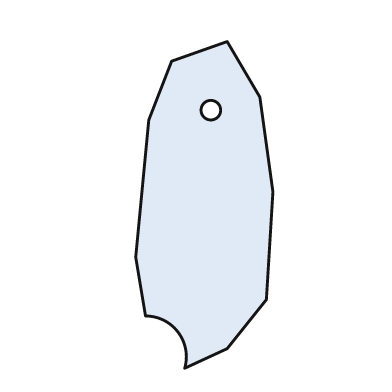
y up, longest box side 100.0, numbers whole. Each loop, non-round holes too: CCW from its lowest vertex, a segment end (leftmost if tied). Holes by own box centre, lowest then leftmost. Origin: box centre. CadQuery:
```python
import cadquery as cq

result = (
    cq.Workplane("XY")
    .moveTo(-6.0, -50.0)
    .lineTo(7.0, -44.0)
    .lineTo(19.0, -29.0)
    .lineTo(21.0, 4.0)
    .lineTo(17.0, 33.0)
    .lineTo(7.0, 50.0)
    .lineTo(-10.0, 44.0)
    .lineTo(-17.0, 26.0)
    .lineTo(-21.0, -16.0)
    .lineTo(-18.0, -34.0)
    .threePointArc((-8.0, -39.0), (-6.0, -50.0))
    .close()
    .moveTo(2.0, 29.0)
    .circle(3.0)
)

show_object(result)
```